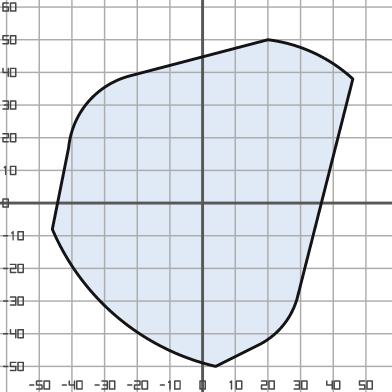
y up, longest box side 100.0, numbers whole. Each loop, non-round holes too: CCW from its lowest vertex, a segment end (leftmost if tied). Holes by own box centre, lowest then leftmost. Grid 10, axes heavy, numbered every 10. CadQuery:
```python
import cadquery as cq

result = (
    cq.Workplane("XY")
    .moveTo(4.0, -50.0)
    .lineTo(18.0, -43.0)
    .threePointArc((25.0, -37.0), (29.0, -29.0))
    .lineTo(46.0, 38.0)
    .threePointArc((34.0, 46.0), (20.0, 50.0))
    .lineTo(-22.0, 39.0)
    .threePointArc((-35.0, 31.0), (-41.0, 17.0))
    .lineTo(-46.0, -8.0)
    .threePointArc((-26.0, -35.0), (4.0, -50.0))
    .close()
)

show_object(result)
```